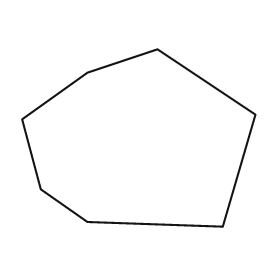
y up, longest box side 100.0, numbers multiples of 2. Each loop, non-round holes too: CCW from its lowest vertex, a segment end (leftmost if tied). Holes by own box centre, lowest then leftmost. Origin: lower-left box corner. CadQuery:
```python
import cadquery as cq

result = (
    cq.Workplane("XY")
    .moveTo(86.0, 0.0)
    .lineTo(100.0, 48.0)
    .lineTo(58.0, 76.0)
    .lineTo(28.0, 66.0)
    .lineTo(0.0, 46.0)
    .lineTo(8.0, 16.0)
    .lineTo(28.0, 2.0)
    .close()
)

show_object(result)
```